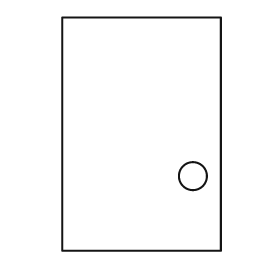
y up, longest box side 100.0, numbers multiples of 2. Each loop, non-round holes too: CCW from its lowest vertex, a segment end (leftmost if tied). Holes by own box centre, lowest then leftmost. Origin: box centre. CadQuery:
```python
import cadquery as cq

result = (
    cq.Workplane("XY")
    .moveTo(-34.0, -50.0)
    .lineTo(34.0, -50.0)
    .lineTo(34.0, 50.0)
    .lineTo(-34.0, 50.0)
    .close()
    .moveTo(22.0, -18.0)
    .circle(6.0)
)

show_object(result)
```